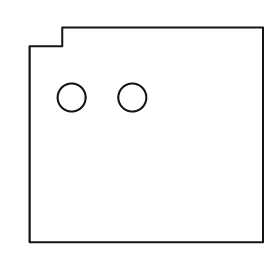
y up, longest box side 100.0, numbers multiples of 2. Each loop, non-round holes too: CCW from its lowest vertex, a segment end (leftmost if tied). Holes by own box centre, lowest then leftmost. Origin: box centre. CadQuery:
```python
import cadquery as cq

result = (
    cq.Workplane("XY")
    .moveTo(-50.0, -46.0)
    .lineTo(50.0, -46.0)
    .lineTo(50.0, 46.0)
    .lineTo(-36.0, 46.0)
    .lineTo(-36.0, 38.0)
    .lineTo(-50.0, 38.0)
    .close()
    .moveTo(-32.0, 16.0)
    .circle(6.0)
    .moveTo(-6.0, 16.0)
    .circle(6.0)
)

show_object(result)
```